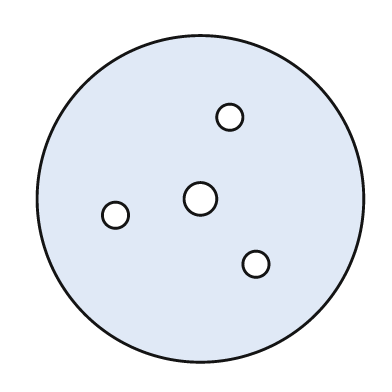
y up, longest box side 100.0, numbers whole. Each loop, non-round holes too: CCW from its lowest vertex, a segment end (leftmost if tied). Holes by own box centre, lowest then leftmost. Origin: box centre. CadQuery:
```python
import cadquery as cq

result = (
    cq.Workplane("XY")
    .moveTo(0.0, 0.0)
    .circle(50.0)
    .moveTo(17.0, -20.0)
    .circle(4.0)
    .moveTo(-26.0, -5.0)
    .circle(4.0)
    .moveTo(0.0, 0.0)
    .circle(5.0)
    .moveTo(9.0, 25.0)
    .circle(4.0)
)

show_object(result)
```